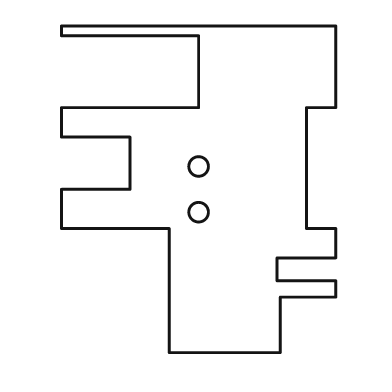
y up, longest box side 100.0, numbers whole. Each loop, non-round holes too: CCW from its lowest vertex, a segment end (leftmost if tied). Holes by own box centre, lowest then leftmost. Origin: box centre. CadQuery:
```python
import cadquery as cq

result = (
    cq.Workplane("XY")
    .moveTo(-9.0, -50.0)
    .lineTo(25.0, -50.0)
    .lineTo(25.0, -33.0)
    .lineTo(42.0, -33.0)
    .lineTo(42.0, -28.0)
    .lineTo(24.0, -28.0)
    .lineTo(24.0, -21.0)
    .lineTo(42.0, -21.0)
    .lineTo(42.0, -12.0)
    .lineTo(33.0, -12.0)
    .lineTo(33.0, 25.0)
    .lineTo(42.0, 25.0)
    .lineTo(42.0, 50.0)
    .lineTo(-42.0, 50.0)
    .lineTo(-42.0, 47.0)
    .lineTo(0.0, 47.0)
    .lineTo(0.0, 25.0)
    .lineTo(-42.0, 25.0)
    .lineTo(-42.0, 16.0)
    .lineTo(-21.0, 16.0)
    .lineTo(-21.0, 0.0)
    .lineTo(-42.0, 0.0)
    .lineTo(-42.0, -12.0)
    .lineTo(-9.0, -12.0)
    .close()
    .moveTo(0.0, -7.0)
    .circle(3.0)
    .moveTo(0.0, 7.0)
    .circle(3.0)
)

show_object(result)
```